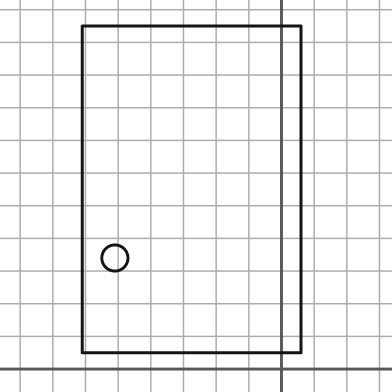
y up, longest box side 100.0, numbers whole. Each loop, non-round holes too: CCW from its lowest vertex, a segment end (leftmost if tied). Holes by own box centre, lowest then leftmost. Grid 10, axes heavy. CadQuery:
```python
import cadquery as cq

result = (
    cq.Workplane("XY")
    .moveTo(-61.0, 5.0)
    .lineTo(6.0, 5.0)
    .lineTo(6.0, 105.0)
    .lineTo(-61.0, 105.0)
    .close()
    .moveTo(-51.0, 34.0)
    .circle(4.0)
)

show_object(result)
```